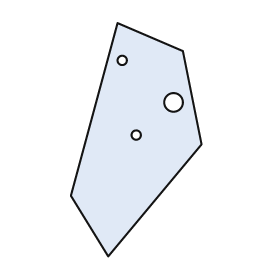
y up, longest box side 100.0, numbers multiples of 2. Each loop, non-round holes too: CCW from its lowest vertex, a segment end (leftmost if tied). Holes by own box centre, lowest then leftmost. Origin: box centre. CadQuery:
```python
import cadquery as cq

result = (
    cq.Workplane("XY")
    .moveTo(-12.0, -50.0)
    .lineTo(28.0, -2.0)
    .lineTo(20.0, 38.0)
    .lineTo(-8.0, 50.0)
    .lineTo(-28.0, -24.0)
    .close()
    .moveTo(0.0, 2.0)
    .circle(2.0)
    .moveTo(16.0, 16.0)
    .circle(4.0)
    .moveTo(-6.0, 34.0)
    .circle(2.0)
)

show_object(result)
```